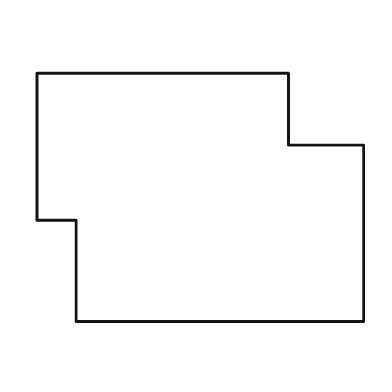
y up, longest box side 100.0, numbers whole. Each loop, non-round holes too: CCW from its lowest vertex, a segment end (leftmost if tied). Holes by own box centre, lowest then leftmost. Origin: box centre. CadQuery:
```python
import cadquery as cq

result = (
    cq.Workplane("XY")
    .moveTo(-38.0, -38.0)
    .lineTo(50.0, -38.0)
    .lineTo(50.0, 16.0)
    .lineTo(27.0, 16.0)
    .lineTo(27.0, 38.0)
    .lineTo(-50.0, 38.0)
    .lineTo(-50.0, -7.0)
    .lineTo(-38.0, -7.0)
    .close()
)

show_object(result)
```